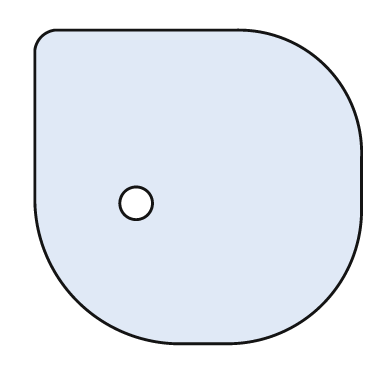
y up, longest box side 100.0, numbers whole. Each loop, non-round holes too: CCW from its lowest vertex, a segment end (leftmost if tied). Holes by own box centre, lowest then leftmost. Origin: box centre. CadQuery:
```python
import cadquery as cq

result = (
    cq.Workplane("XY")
    .moveTo(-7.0, -48.0)
    .lineTo(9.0, -48.0)
    .threePointArc((38.0, -36.0), (50.0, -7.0))
    .lineTo(50.0, 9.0)
    .threePointArc((39.0, 37.0), (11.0, 48.0))
    .lineTo(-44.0, 48.0)
    .threePointArc((-48.0, 46.0), (-50.0, 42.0))
    .lineTo(-50.0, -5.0)
    .threePointArc((-37.0, -35.0), (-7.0, -48.0))
    .close()
    .moveTo(-19.0, -5.0)
    .circle(5.0)
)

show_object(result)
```